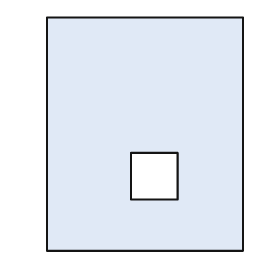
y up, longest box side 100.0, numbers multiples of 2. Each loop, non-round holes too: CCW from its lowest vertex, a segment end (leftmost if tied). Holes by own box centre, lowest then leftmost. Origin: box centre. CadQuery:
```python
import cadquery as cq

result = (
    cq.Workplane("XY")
    .moveTo(-42.0, -50.0)
    .lineTo(42.0, -50.0)
    .lineTo(42.0, 50.0)
    .lineTo(-42.0, 50.0)
    .close()
    .moveTo(-6.0, -28.0)
    .lineTo(14.0, -28.0)
    .lineTo(14.0, -8.0)
    .lineTo(-6.0, -8.0)
    .close()
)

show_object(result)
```